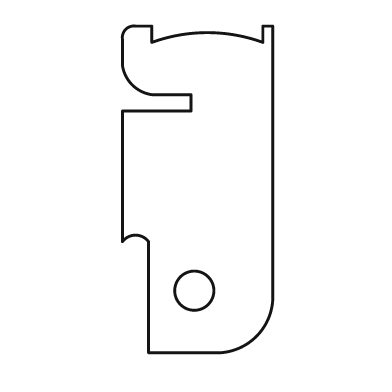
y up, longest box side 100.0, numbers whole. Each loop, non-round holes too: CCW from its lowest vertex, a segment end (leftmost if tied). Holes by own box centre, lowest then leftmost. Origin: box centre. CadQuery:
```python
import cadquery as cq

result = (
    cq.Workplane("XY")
    .moveTo(-15.0, -50.0)
    .lineTo(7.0, -50.0)
    .threePointArc((18.0, -45.0), (23.0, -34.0))
    .lineTo(23.0, 50.0)
    .lineTo(20.0, 50.0)
    .lineTo(20.0, 45.0)
    .threePointArc((3.0, 48.0), (-14.0, 45.0))
    .lineTo(-14.0, 50.0)
    .lineTo(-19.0, 50.0)
    .threePointArc((-22.0, 49.0), (-23.0, 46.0))
    .lineTo(-23.0, 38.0)
    .threePointArc((-20.0, 32.0), (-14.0, 29.0))
    .lineTo(-2.0, 29.0)
    .lineTo(-2.0, 24.0)
    .lineTo(-23.0, 24.0)
    .lineTo(-23.0, -16.0)
    .threePointArc((-19.0, -14.0), (-15.0, -16.0))
    .close()
    .moveTo(-1.0, -31.0)
    .circle(6.0)
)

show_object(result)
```